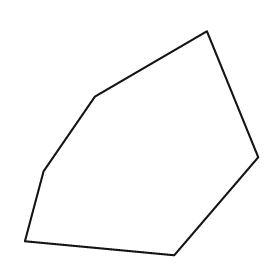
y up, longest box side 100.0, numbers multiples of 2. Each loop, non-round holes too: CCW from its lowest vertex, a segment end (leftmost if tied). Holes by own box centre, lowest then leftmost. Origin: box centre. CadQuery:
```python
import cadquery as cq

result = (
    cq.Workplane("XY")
    .moveTo(14.0, -48.0)
    .lineTo(50.0, -6.0)
    .lineTo(28.0, 48.0)
    .lineTo(-20.0, 20.0)
    .lineTo(-42.0, -12.0)
    .lineTo(-50.0, -42.0)
    .close()
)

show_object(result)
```